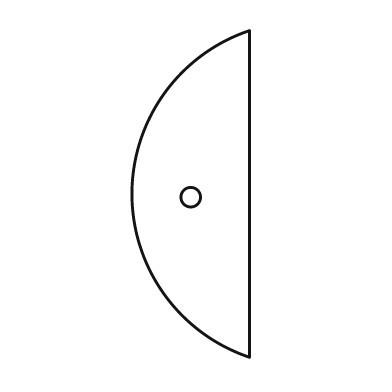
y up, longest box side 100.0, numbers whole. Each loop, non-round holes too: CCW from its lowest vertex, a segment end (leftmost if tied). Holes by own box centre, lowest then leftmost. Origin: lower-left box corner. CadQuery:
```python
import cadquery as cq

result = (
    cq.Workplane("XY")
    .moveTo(36.0, 0.0)
    .lineTo(36.0, 100.0)
    .threePointArc((0.0, 50.0), (36.0, 0.0))
    .close()
    .moveTo(18.0, 49.0)
    .circle(3.0)
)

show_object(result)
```